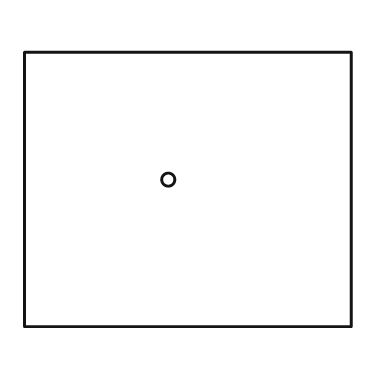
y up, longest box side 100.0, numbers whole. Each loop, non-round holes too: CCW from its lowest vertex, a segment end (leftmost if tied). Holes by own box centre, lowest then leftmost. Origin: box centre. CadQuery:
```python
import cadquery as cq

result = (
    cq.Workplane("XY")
    .moveTo(-50.0, -42.0)
    .lineTo(50.0, -42.0)
    .lineTo(50.0, 42.0)
    .lineTo(-50.0, 42.0)
    .close()
    .moveTo(-6.0, 3.0)
    .circle(2.0)
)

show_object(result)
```